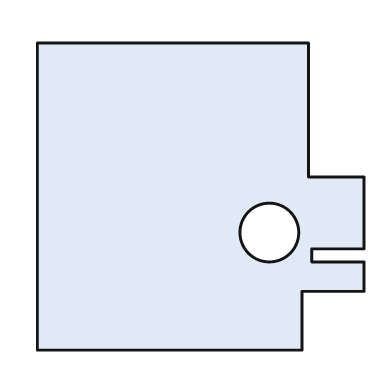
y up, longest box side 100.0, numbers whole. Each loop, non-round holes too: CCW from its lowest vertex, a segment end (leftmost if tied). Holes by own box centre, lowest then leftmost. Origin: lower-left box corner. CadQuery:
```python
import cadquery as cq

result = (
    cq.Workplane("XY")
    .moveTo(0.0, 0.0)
    .lineTo(81.0, 0.0)
    .lineTo(81.0, 18.0)
    .lineTo(100.0, 18.0)
    .lineTo(100.0, 27.0)
    .lineTo(84.0, 27.0)
    .lineTo(84.0, 31.0)
    .lineTo(100.0, 31.0)
    .lineTo(100.0, 53.0)
    .lineTo(83.0, 53.0)
    .lineTo(83.0, 94.0)
    .lineTo(0.0, 94.0)
    .close()
    .moveTo(71.0, 36.0)
    .circle(9.0)
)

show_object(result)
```